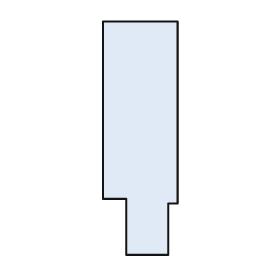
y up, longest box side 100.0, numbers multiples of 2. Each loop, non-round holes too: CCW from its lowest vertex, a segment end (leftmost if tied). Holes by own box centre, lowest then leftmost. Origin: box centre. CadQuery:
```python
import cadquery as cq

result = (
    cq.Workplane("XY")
    .moveTo(-6.0, -50.0)
    .lineTo(12.0, -50.0)
    .lineTo(12.0, -28.0)
    .lineTo(16.0, -28.0)
    .lineTo(16.0, 50.0)
    .lineTo(-16.0, 50.0)
    .lineTo(-16.0, -26.0)
    .lineTo(-6.0, -26.0)
    .close()
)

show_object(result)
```